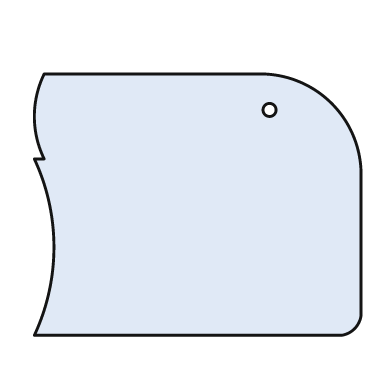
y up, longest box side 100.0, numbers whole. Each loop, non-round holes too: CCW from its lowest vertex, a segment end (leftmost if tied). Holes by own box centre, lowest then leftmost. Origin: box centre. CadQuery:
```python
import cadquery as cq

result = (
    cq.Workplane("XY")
    .moveTo(-50.0, -40.0)
    .lineTo(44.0, -40.0)
    .threePointArc((48.0, -38.0), (50.0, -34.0))
    .lineTo(50.0, 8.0)
    .threePointArc((41.0, 31.0), (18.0, 40.0))
    .lineTo(-47.0, 40.0)
    .threePointArc((-50.0, 27.0), (-47.0, 14.0))
    .lineTo(-50.0, 14.0)
    .threePointArc((-44.0, -13.0), (-50.0, -40.0))
    .close()
    .moveTo(22.0, 29.0)
    .circle(2.0)
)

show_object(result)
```